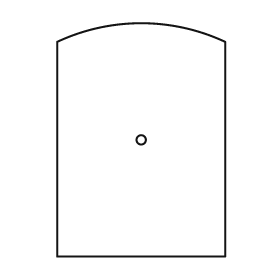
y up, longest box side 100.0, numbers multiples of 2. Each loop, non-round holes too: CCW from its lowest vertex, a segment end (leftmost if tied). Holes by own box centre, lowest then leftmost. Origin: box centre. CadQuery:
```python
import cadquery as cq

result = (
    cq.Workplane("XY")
    .moveTo(-36.0, -50.0)
    .lineTo(36.0, -50.0)
    .lineTo(36.0, 42.0)
    .threePointArc((0.0, 50.0), (-36.0, 42.0))
    .close()
    .moveTo(0.0, 0.0)
    .circle(2.0)
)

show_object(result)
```